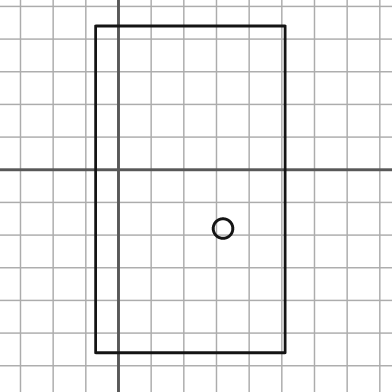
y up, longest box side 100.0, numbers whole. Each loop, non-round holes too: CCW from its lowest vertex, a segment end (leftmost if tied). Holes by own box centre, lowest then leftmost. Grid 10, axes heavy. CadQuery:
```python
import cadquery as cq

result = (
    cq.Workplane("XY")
    .moveTo(-7.0, -56.0)
    .lineTo(51.0, -56.0)
    .lineTo(51.0, 44.0)
    .lineTo(-7.0, 44.0)
    .close()
    .moveTo(32.0, -18.0)
    .circle(3.0)
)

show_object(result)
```